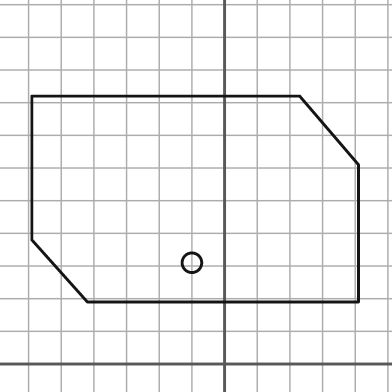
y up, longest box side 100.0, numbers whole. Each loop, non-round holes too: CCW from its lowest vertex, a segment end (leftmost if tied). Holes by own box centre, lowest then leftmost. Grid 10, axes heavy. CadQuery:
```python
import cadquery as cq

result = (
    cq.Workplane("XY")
    .moveTo(-42.0, 19.0)
    .lineTo(41.0, 19.0)
    .lineTo(41.0, 61.0)
    .lineTo(23.0, 82.0)
    .lineTo(-59.0, 82.0)
    .lineTo(-59.0, 38.0)
    .close()
    .moveTo(-10.0, 31.0)
    .circle(3.0)
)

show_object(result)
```